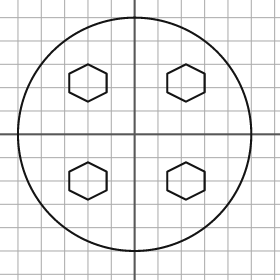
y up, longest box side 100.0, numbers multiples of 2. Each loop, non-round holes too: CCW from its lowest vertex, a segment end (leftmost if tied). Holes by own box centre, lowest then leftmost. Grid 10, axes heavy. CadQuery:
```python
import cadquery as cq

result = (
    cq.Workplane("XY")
    .moveTo(0.0, 0.0)
    .circle(50.0)
    .moveTo(-20.0, -28.0)
    .lineTo(-12.0, -24.0)
    .lineTo(-12.0, -16.0)
    .lineTo(-20.0, -12.0)
    .lineTo(-28.0, -16.0)
    .lineTo(-28.0, -24.0)
    .close()
    .moveTo(22.0, -28.0)
    .lineTo(30.0, -24.0)
    .lineTo(30.0, -16.0)
    .lineTo(22.0, -12.0)
    .lineTo(14.0, -16.0)
    .lineTo(14.0, -24.0)
    .close()
    .moveTo(-20.0, 14.0)
    .lineTo(-12.0, 18.0)
    .lineTo(-12.0, 26.0)
    .lineTo(-20.0, 30.0)
    .lineTo(-28.0, 26.0)
    .lineTo(-28.0, 18.0)
    .close()
    .moveTo(22.0, 14.0)
    .lineTo(30.0, 18.0)
    .lineTo(30.0, 26.0)
    .lineTo(22.0, 30.0)
    .lineTo(14.0, 26.0)
    .lineTo(14.0, 18.0)
    .close()
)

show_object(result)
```